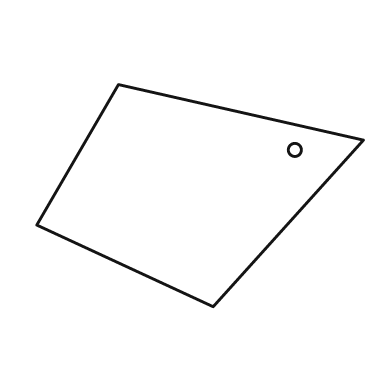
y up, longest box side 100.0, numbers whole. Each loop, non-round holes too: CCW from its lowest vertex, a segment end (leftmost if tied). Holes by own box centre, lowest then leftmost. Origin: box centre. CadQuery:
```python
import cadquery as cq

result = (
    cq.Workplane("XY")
    .moveTo(4.0, -34.0)
    .lineTo(50.0, 17.0)
    .lineTo(-25.0, 34.0)
    .lineTo(-50.0, -9.0)
    .close()
    .moveTo(29.0, 14.0)
    .circle(2.0)
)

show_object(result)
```